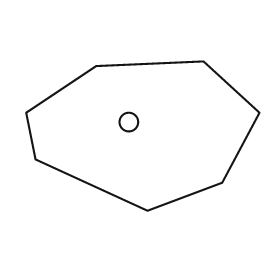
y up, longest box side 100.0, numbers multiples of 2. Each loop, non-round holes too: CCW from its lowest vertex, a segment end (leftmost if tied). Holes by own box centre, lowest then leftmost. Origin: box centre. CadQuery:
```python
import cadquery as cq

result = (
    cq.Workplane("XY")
    .moveTo(2.0, -32.0)
    .lineTo(34.0, -20.0)
    .lineTo(50.0, 10.0)
    .lineTo(26.0, 32.0)
    .lineTo(-20.0, 30.0)
    .lineTo(-50.0, 10.0)
    .lineTo(-46.0, -10.0)
    .close()
    .moveTo(-6.0, 6.0)
    .circle(4.0)
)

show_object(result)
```